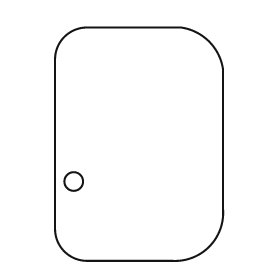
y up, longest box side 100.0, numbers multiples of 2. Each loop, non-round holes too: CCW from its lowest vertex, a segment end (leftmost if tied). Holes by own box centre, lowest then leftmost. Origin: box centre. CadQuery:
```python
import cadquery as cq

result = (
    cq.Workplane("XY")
    .moveTo(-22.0, -50.0)
    .lineTo(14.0, -50.0)
    .threePointArc((30.0, -44.0), (36.0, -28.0))
    .lineTo(36.0, 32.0)
    .threePointArc((30.0, 44.0), (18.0, 50.0))
    .lineTo(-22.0, 50.0)
    .threePointArc((-32.0, 46.0), (-36.0, 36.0))
    .lineTo(-36.0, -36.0)
    .threePointArc((-32.0, -46.0), (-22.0, -50.0))
    .close()
    .moveTo(-28.0, -16.0)
    .circle(4.0)
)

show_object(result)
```